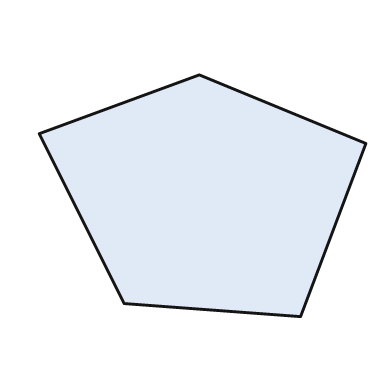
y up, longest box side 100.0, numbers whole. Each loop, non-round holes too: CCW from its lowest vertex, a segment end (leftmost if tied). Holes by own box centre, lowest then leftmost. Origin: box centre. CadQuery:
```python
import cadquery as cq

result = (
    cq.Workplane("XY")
    .moveTo(30.0, -37.0)
    .lineTo(50.0, 16.0)
    .lineTo(-1.0, 37.0)
    .lineTo(-50.0, 19.0)
    .lineTo(-24.0, -33.0)
    .close()
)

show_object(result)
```